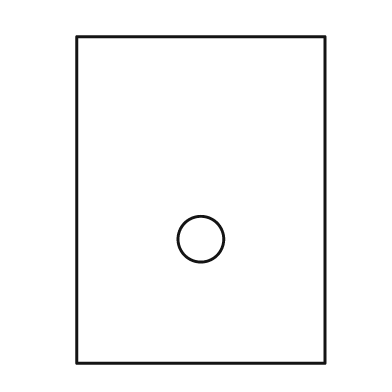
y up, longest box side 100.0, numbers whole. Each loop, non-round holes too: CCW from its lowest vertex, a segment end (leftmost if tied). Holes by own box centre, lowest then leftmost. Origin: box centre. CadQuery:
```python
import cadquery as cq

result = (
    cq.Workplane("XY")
    .moveTo(-38.0, -50.0)
    .lineTo(38.0, -50.0)
    .lineTo(38.0, 50.0)
    .lineTo(-38.0, 50.0)
    .close()
    .moveTo(0.0, -12.0)
    .circle(7.0)
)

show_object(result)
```